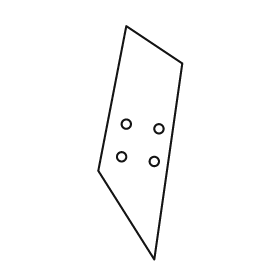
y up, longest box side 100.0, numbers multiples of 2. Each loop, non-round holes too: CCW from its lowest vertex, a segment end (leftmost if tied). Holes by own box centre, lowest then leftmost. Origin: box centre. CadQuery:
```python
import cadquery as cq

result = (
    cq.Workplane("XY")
    .moveTo(6.0, -50.0)
    .lineTo(18.0, 34.0)
    .lineTo(-6.0, 50.0)
    .lineTo(-18.0, -12.0)
    .close()
    .moveTo(6.0, -8.0)
    .circle(2.0)
    .moveTo(-8.0, -6.0)
    .circle(2.0)
    .moveTo(8.0, 6.0)
    .circle(2.0)
    .moveTo(-6.0, 8.0)
    .circle(2.0)
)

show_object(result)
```